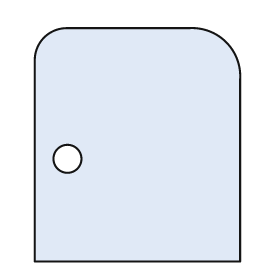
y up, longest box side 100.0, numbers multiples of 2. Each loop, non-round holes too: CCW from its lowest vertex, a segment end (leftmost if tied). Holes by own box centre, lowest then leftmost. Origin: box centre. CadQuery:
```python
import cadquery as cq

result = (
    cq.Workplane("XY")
    .moveTo(-44.0, -50.0)
    .lineTo(44.0, -50.0)
    .lineTo(44.0, 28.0)
    .threePointArc((38.0, 44.0), (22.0, 50.0))
    .lineTo(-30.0, 50.0)
    .threePointArc((-40.0, 46.0), (-44.0, 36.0))
    .close()
    .moveTo(-30.0, -6.0)
    .circle(6.0)
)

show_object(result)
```